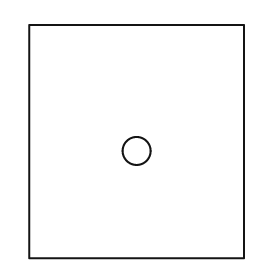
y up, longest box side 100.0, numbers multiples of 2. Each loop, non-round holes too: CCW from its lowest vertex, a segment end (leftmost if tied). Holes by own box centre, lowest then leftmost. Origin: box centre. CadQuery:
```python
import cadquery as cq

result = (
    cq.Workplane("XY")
    .moveTo(-46.0, -50.0)
    .lineTo(46.0, -50.0)
    .lineTo(46.0, 50.0)
    .lineTo(-46.0, 50.0)
    .close()
    .moveTo(0.0, -4.0)
    .circle(6.0)
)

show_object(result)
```